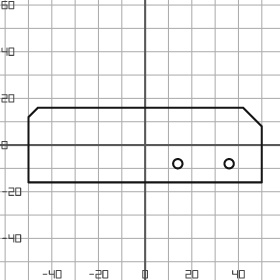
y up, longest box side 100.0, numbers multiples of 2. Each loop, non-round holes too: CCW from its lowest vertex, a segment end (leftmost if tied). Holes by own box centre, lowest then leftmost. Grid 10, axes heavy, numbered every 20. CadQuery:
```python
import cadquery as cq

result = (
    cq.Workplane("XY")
    .moveTo(-50.0, -16.0)
    .lineTo(50.0, -16.0)
    .lineTo(50.0, 8.0)
    .lineTo(42.0, 16.0)
    .lineTo(-46.0, 16.0)
    .lineTo(-50.0, 12.0)
    .close()
    .moveTo(14.0, -8.0)
    .circle(2.0)
    .moveTo(36.0, -8.0)
    .circle(2.0)
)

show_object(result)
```